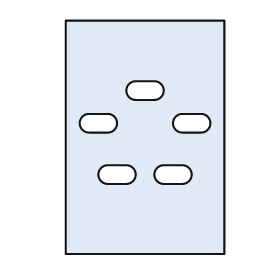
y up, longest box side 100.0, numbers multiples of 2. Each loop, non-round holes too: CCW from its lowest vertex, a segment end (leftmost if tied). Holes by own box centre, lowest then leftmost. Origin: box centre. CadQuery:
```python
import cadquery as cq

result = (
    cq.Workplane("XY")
    .moveTo(-34.0, -50.0)
    .lineTo(34.0, -50.0)
    .lineTo(34.0, 50.0)
    .lineTo(-34.0, 50.0)
    .close()
    .moveTo(-16.0, -20.0)
    .lineTo(-8.0, -20.0)
    .threePointArc((-4.0, -16.0), (-8.0, -12.0))
    .lineTo(-16.0, -12.0)
    .threePointArc((-20.0, -16.0), (-16.0, -20.0))
    .close()
    .moveTo(8.0, -20.0)
    .lineTo(16.0, -20.0)
    .threePointArc((20.0, -16.0), (16.0, -12.0))
    .lineTo(8.0, -12.0)
    .threePointArc((4.0, -16.0), (8.0, -20.0))
    .close()
    .moveTo(-24.0, 2.0)
    .lineTo(-16.0, 2.0)
    .threePointArc((-12.0, 6.0), (-16.0, 10.0))
    .lineTo(-24.0, 10.0)
    .threePointArc((-28.0, 6.0), (-24.0, 2.0))
    .close()
    .moveTo(16.0, 2.0)
    .lineTo(24.0, 2.0)
    .threePointArc((28.0, 6.0), (24.0, 10.0))
    .lineTo(16.0, 10.0)
    .threePointArc((12.0, 6.0), (16.0, 2.0))
    .close()
    .moveTo(-4.0, 16.0)
    .lineTo(4.0, 16.0)
    .threePointArc((8.0, 20.0), (4.0, 24.0))
    .lineTo(-4.0, 24.0)
    .threePointArc((-8.0, 20.0), (-4.0, 16.0))
    .close()
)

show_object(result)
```